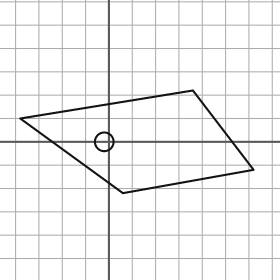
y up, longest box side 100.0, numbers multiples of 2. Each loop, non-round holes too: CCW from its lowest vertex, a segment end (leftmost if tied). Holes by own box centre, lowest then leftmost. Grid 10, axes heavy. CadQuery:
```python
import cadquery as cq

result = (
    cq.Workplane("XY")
    .moveTo(6.0, -22.0)
    .lineTo(62.0, -12.0)
    .lineTo(36.0, 22.0)
    .lineTo(-38.0, 10.0)
    .close()
    .moveTo(-2.0, 0.0)
    .circle(4.0)
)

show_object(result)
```